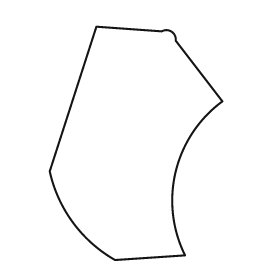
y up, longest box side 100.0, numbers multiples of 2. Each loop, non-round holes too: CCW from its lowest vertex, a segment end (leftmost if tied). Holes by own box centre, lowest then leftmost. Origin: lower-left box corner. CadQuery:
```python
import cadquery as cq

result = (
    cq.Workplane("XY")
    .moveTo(28.0, 0.0)
    .lineTo(58.0, 2.0)
    .threePointArc((54.0, 38.0), (74.0, 68.0))
    .lineTo(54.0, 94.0)
    .threePointArc((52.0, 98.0), (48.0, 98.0))
    .lineTo(20.0, 100.0)
    .lineTo(0.0, 38.0)
    .threePointArc((10.0, 16.0), (28.0, 0.0))
    .close()
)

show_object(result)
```